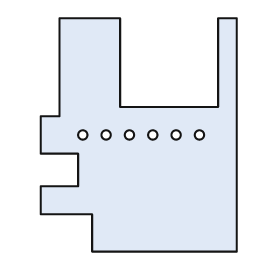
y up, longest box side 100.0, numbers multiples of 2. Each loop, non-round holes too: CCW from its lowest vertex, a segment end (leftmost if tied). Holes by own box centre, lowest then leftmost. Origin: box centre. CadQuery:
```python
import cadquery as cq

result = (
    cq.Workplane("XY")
    .moveTo(-20.0, -50.0)
    .lineTo(42.0, -50.0)
    .lineTo(42.0, 50.0)
    .lineTo(34.0, 50.0)
    .lineTo(34.0, 12.0)
    .lineTo(-8.0, 12.0)
    .lineTo(-8.0, 50.0)
    .lineTo(-34.0, 50.0)
    .lineTo(-34.0, 8.0)
    .lineTo(-42.0, 8.0)
    .lineTo(-42.0, -8.0)
    .lineTo(-26.0, -8.0)
    .lineTo(-26.0, -22.0)
    .lineTo(-42.0, -22.0)
    .lineTo(-42.0, -34.0)
    .lineTo(-20.0, -34.0)
    .close()
    .moveTo(-24.0, 0.0)
    .circle(2.0)
    .moveTo(-14.0, 0.0)
    .circle(2.0)
    .moveTo(-4.0, 0.0)
    .circle(2.0)
    .moveTo(6.0, 0.0)
    .circle(2.0)
    .moveTo(16.0, 0.0)
    .circle(2.0)
    .moveTo(26.0, 0.0)
    .circle(2.0)
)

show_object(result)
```